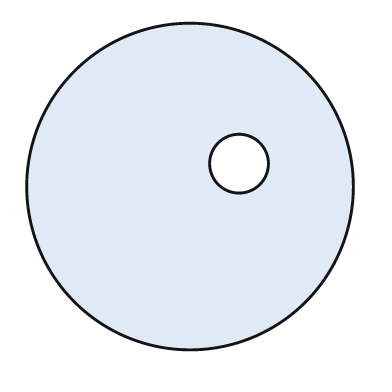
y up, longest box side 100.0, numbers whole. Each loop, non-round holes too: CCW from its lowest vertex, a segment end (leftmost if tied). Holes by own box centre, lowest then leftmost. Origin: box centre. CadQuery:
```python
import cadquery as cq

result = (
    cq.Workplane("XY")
    .moveTo(0.0, 0.0)
    .circle(50.0)
    .moveTo(15.0, 7.0)
    .circle(9.0)
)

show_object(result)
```